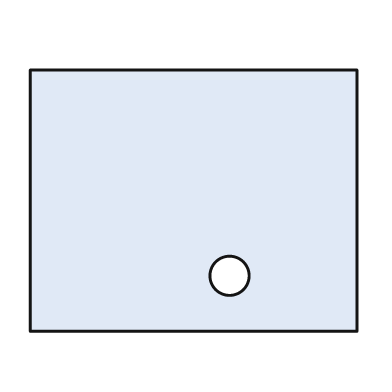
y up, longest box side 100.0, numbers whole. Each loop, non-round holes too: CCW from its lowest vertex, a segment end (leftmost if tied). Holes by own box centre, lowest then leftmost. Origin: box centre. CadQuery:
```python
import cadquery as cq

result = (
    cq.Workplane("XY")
    .moveTo(-50.0, -40.0)
    .lineTo(50.0, -40.0)
    .lineTo(50.0, 40.0)
    .lineTo(-50.0, 40.0)
    .close()
    .moveTo(11.0, -23.0)
    .circle(6.0)
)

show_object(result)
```